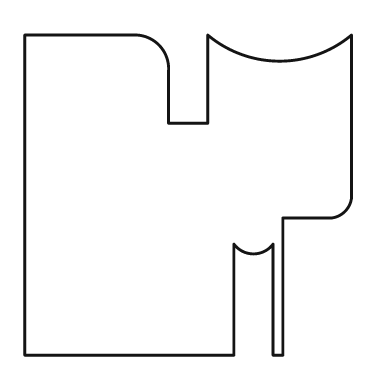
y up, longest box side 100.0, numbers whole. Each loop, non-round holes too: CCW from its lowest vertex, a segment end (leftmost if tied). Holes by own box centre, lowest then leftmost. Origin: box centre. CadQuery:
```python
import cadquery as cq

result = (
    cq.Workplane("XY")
    .moveTo(-50.0, -49.0)
    .lineTo(14.0, -49.0)
    .lineTo(14.0, -15.0)
    .threePointArc((20.0, -18.0), (26.0, -15.0))
    .lineTo(26.0, -49.0)
    .lineTo(29.0, -49.0)
    .lineTo(29.0, -7.0)
    .lineTo(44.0, -7.0)
    .threePointArc((48.0, -5.0), (50.0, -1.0))
    .lineTo(50.0, 49.0)
    .threePointArc((28.0, 41.0), (6.0, 49.0))
    .lineTo(6.0, 22.0)
    .lineTo(-6.0, 22.0)
    .lineTo(-6.0, 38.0)
    .threePointArc((-9.0, 46.0), (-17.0, 49.0))
    .lineTo(-50.0, 49.0)
    .close()
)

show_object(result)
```